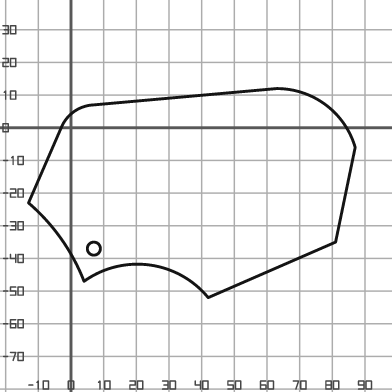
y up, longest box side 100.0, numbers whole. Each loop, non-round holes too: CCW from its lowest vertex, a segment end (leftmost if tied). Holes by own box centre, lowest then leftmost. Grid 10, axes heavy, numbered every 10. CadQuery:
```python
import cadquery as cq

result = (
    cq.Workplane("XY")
    .moveTo(42.0, -52.0)
    .lineTo(81.0, -35.0)
    .lineTo(87.0, -6.0)
    .threePointArc((78.0, 7.0), (63.0, 12.0))
    .lineTo(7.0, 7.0)
    .threePointArc((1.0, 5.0), (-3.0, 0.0))
    .lineTo(-13.0, -23.0)
    .threePointArc((-3.0, -34.0), (4.0, -47.0))
    .threePointArc((24.0, -42.0), (42.0, -52.0))
    .close()
    .moveTo(7.0, -37.0)
    .circle(2.0)
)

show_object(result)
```